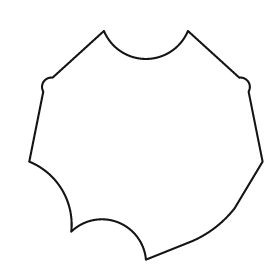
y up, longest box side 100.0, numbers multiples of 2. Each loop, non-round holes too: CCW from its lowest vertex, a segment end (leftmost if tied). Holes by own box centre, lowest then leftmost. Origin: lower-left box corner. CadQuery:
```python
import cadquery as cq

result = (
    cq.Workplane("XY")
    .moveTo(50.0, 0.0)
    .lineTo(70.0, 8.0)
    .threePointArc((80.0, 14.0), (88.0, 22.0))
    .lineTo(100.0, 42.0)
    .lineTo(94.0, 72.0)
    .threePointArc((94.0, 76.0), (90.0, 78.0))
    .lineTo(68.0, 98.0)
    .threePointArc((50.0, 86.0), (32.0, 98.0))
    .lineTo(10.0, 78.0)
    .threePointArc((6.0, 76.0), (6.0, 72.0))
    .lineTo(0.0, 42.0)
    .threePointArc((14.0, 30.0), (18.0, 12.0))
    .threePointArc((38.0, 16.0), (50.0, 0.0))
    .close()
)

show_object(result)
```